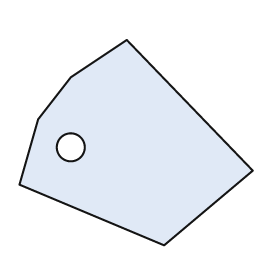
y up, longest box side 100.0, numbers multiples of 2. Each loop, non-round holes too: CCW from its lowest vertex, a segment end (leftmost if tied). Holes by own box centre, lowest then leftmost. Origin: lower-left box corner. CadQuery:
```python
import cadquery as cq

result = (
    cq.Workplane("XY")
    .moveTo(62.0, 0.0)
    .lineTo(100.0, 32.0)
    .lineTo(46.0, 88.0)
    .lineTo(22.0, 72.0)
    .lineTo(8.0, 54.0)
    .lineTo(0.0, 26.0)
    .close()
    .moveTo(22.0, 42.0)
    .circle(6.0)
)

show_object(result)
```